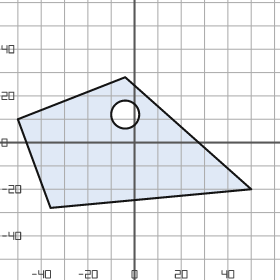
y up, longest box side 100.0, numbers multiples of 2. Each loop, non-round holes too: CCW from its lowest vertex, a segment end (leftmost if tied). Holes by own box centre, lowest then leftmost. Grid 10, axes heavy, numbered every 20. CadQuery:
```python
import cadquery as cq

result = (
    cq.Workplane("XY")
    .moveTo(-36.0, -28.0)
    .lineTo(50.0, -20.0)
    .lineTo(-4.0, 28.0)
    .lineTo(-50.0, 10.0)
    .close()
    .moveTo(-4.0, 12.0)
    .circle(6.0)
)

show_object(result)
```